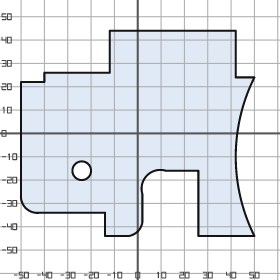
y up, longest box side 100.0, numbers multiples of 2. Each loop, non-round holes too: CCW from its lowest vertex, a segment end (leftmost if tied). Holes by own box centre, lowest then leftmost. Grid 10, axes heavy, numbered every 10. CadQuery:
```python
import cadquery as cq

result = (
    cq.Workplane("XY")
    .moveTo(-14.0, -44.0)
    .lineTo(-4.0, -44.0)
    .threePointArc((0.0, -42.0), (2.0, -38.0))
    .lineTo(2.0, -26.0)
    .threePointArc((4.0, -18.0), (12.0, -16.0))
    .lineTo(26.0, -16.0)
    .lineTo(26.0, -44.0)
    .lineTo(50.0, -44.0)
    .threePointArc((42.0, -10.0), (50.0, 24.0))
    .lineTo(42.0, 24.0)
    .lineTo(42.0, 44.0)
    .lineTo(-12.0, 44.0)
    .lineTo(-12.0, 26.0)
    .lineTo(-40.0, 26.0)
    .lineTo(-40.0, 22.0)
    .lineTo(-50.0, 22.0)
    .lineTo(-50.0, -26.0)
    .threePointArc((-48.0, -32.0), (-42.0, -34.0))
    .lineTo(-14.0, -34.0)
    .close()
    .moveTo(-24.0, -16.0)
    .circle(4.0)
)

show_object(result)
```